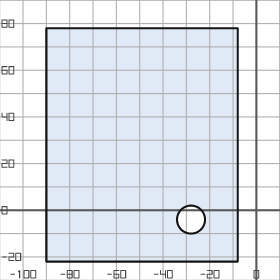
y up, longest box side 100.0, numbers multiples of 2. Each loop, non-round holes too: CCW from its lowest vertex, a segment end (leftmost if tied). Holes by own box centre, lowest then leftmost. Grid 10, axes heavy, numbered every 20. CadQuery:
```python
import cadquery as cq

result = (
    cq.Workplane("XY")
    .moveTo(-90.0, -22.0)
    .lineTo(-8.0, -22.0)
    .lineTo(-8.0, 78.0)
    .lineTo(-90.0, 78.0)
    .close()
    .moveTo(-28.0, -4.0)
    .circle(6.0)
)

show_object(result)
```